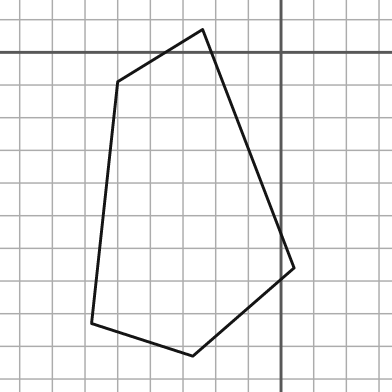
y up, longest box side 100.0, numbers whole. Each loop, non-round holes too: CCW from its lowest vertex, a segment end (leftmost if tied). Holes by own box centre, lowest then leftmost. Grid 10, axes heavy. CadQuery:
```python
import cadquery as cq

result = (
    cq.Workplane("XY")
    .moveTo(-27.0, -93.0)
    .lineTo(4.0, -66.0)
    .lineTo(-24.0, 7.0)
    .lineTo(-50.0, -9.0)
    .lineTo(-58.0, -83.0)
    .close()
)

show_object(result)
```